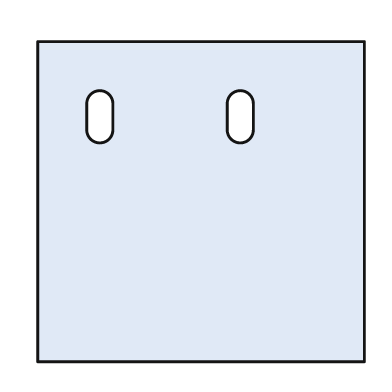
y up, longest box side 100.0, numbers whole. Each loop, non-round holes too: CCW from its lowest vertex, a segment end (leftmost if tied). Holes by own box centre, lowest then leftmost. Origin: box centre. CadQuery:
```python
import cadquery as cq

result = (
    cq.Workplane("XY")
    .moveTo(-50.0, -49.0)
    .lineTo(50.0, -49.0)
    .lineTo(50.0, 49.0)
    .lineTo(-50.0, 49.0)
    .close()
    .moveTo(-35.0, 22.0)
    .threePointArc((-31.0, 18.0), (-27.0, 22.0))
    .lineTo(-27.0, 30.0)
    .threePointArc((-31.0, 34.0), (-35.0, 30.0))
    .close()
    .moveTo(8.0, 22.0)
    .threePointArc((12.0, 18.0), (16.0, 22.0))
    .lineTo(16.0, 30.0)
    .threePointArc((12.0, 34.0), (8.0, 30.0))
    .close()
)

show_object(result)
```